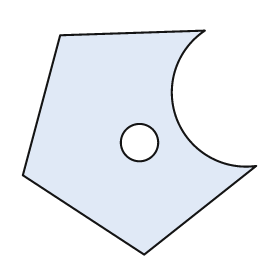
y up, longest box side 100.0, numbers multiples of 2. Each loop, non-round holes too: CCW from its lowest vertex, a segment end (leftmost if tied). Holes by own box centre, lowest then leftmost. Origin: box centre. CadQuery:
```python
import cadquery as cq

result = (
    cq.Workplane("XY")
    .moveTo(2.0, -48.0)
    .lineTo(50.0, -10.0)
    .threePointArc((16.0, 10.0), (28.0, 48.0))
    .lineTo(-34.0, 46.0)
    .lineTo(-50.0, -14.0)
    .close()
    .moveTo(0.0, 0.0)
    .circle(8.0)
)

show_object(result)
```